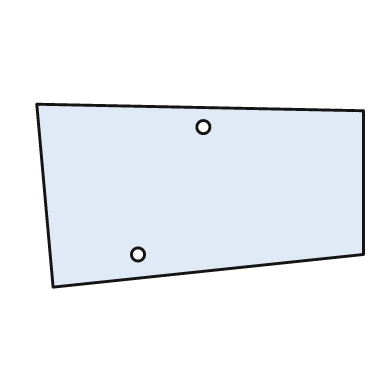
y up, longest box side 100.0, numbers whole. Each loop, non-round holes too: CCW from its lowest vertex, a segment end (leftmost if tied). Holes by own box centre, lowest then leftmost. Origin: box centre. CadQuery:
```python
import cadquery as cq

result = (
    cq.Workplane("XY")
    .moveTo(-45.0, -28.0)
    .lineTo(50.0, -18.0)
    .lineTo(50.0, 26.0)
    .lineTo(-50.0, 28.0)
    .close()
    .moveTo(-19.0, -18.0)
    .circle(2.0)
    .moveTo(1.0, 21.0)
    .circle(2.0)
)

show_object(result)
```